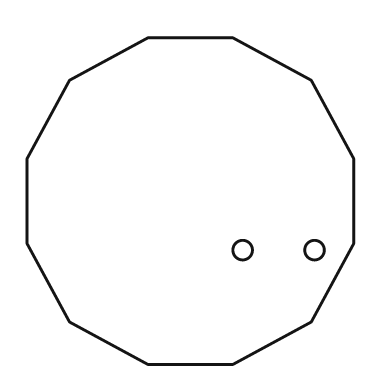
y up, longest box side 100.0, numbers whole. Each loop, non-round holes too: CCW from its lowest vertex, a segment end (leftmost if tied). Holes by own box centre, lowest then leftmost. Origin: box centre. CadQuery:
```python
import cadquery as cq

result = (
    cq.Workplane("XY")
    .moveTo(-13.0, -50.0)
    .lineTo(13.0, -50.0)
    .lineTo(37.0, -37.0)
    .lineTo(50.0, -13.0)
    .lineTo(50.0, 13.0)
    .lineTo(37.0, 37.0)
    .lineTo(13.0, 50.0)
    .lineTo(-13.0, 50.0)
    .lineTo(-37.0, 37.0)
    .lineTo(-50.0, 13.0)
    .lineTo(-50.0, -13.0)
    .lineTo(-37.0, -37.0)
    .close()
    .moveTo(16.0, -15.0)
    .circle(3.0)
    .moveTo(38.0, -15.0)
    .circle(3.0)
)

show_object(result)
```